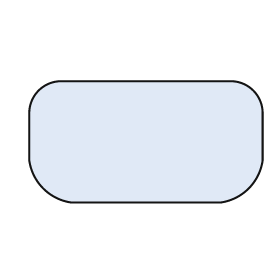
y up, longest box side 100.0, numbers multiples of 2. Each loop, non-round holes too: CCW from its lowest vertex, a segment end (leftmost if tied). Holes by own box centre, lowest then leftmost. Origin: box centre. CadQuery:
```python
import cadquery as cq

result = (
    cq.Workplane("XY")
    .moveTo(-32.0, -26.0)
    .lineTo(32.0, -26.0)
    .threePointArc((44.0, -20.0), (50.0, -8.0))
    .lineTo(50.0, 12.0)
    .threePointArc((46.0, 22.0), (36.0, 26.0))
    .lineTo(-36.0, 26.0)
    .threePointArc((-46.0, 22.0), (-50.0, 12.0))
    .lineTo(-50.0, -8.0)
    .threePointArc((-44.0, -20.0), (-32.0, -26.0))
    .close()
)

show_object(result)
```